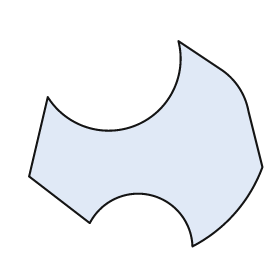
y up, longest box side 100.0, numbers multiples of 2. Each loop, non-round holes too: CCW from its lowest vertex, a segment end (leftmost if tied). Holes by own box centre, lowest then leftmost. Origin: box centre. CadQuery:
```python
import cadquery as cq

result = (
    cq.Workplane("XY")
    .moveTo(20.0, -44.0)
    .threePointArc((38.0, -30.0), (50.0, -10.0))
    .lineTo(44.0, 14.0)
    .threePointArc((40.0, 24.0), (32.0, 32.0))
    .lineTo(14.0, 44.0)
    .threePointArc((-4.0, 8.0), (-42.0, 20.0))
    .lineTo(-50.0, -14.0)
    .lineTo(-24.0, -34.0)
    .threePointArc((2.0, -22.0), (20.0, -44.0))
    .close()
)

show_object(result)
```